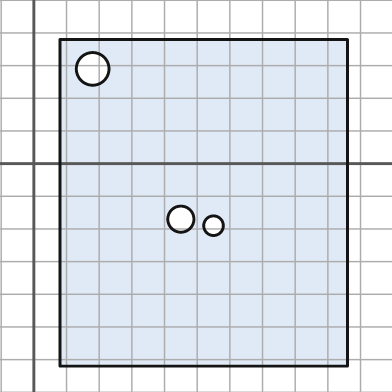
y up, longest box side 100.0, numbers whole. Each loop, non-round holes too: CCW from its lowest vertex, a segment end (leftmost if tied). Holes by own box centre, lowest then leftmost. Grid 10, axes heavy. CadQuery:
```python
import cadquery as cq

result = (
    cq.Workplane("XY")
    .moveTo(8.0, -62.0)
    .lineTo(96.0, -62.0)
    .lineTo(96.0, 38.0)
    .lineTo(8.0, 38.0)
    .close()
    .moveTo(55.0, -19.0)
    .circle(3.0)
    .moveTo(45.0, -17.0)
    .circle(4.0)
    .moveTo(18.0, 29.0)
    .circle(5.0)
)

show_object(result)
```